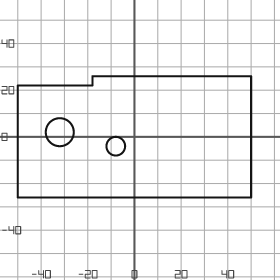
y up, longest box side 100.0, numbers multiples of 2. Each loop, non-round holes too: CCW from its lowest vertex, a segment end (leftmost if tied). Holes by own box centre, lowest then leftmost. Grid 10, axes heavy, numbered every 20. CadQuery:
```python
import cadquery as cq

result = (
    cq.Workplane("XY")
    .moveTo(-50.0, -26.0)
    .lineTo(50.0, -26.0)
    .lineTo(50.0, 26.0)
    .lineTo(-18.0, 26.0)
    .lineTo(-18.0, 22.0)
    .lineTo(-50.0, 22.0)
    .close()
    .moveTo(-8.0, -4.0)
    .circle(4.0)
    .moveTo(-32.0, 2.0)
    .circle(6.0)
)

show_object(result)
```